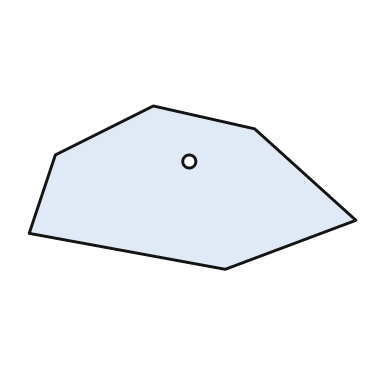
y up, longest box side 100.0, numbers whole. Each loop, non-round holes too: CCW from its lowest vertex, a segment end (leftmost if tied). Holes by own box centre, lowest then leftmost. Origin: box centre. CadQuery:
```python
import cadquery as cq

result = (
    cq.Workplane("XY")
    .moveTo(10.0, -25.0)
    .lineTo(50.0, -10.0)
    .lineTo(19.0, 18.0)
    .lineTo(-12.0, 25.0)
    .lineTo(-42.0, 10.0)
    .lineTo(-50.0, -14.0)
    .close()
    .moveTo(-1.0, 8.0)
    .circle(2.0)
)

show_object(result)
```